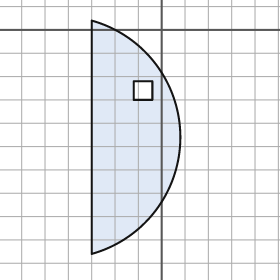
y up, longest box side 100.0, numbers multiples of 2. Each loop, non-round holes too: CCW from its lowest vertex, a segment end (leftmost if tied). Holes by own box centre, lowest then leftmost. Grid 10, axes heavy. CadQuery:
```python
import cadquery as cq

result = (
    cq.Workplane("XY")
    .moveTo(-30.0, -96.0)
    .threePointArc((8.0, -46.0), (-30.0, 4.0))
    .close()
    .moveTo(-12.0, -30.0)
    .lineTo(-4.0, -30.0)
    .lineTo(-4.0, -22.0)
    .lineTo(-12.0, -22.0)
    .close()
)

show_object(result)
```